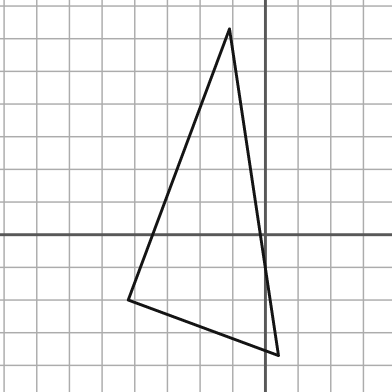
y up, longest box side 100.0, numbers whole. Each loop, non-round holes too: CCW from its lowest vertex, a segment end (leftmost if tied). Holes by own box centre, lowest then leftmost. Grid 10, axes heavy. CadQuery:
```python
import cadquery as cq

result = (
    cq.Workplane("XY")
    .moveTo(4.0, -37.0)
    .lineTo(-11.0, 63.0)
    .lineTo(-42.0, -20.0)
    .close()
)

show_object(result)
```